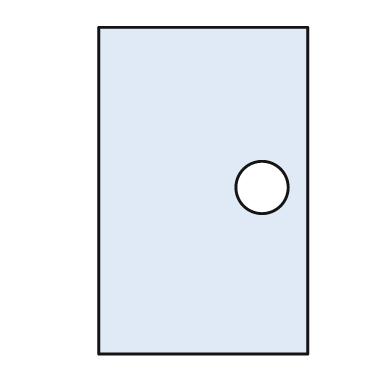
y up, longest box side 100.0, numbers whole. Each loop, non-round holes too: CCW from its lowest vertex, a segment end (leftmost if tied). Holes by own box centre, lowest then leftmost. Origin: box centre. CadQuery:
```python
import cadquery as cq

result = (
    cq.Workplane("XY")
    .moveTo(-32.0, -50.0)
    .lineTo(32.0, -50.0)
    .lineTo(32.0, 50.0)
    .lineTo(-32.0, 50.0)
    .close()
    .moveTo(18.0, 1.0)
    .circle(8.0)
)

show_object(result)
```